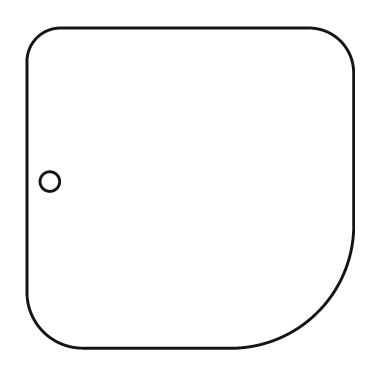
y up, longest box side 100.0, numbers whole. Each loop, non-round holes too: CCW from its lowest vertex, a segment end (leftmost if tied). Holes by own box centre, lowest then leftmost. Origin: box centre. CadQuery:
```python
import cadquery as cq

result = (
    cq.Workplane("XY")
    .moveTo(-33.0, -49.0)
    .lineTo(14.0, -49.0)
    .threePointArc((39.0, -38.0), (50.0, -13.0))
    .lineTo(50.0, 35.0)
    .threePointArc((46.0, 45.0), (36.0, 49.0))
    .lineTo(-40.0, 49.0)
    .threePointArc((-47.0, 46.0), (-50.0, 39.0))
    .lineTo(-50.0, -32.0)
    .threePointArc((-45.0, -44.0), (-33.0, -49.0))
    .close()
    .moveTo(-43.0, 2.0)
    .circle(3.0)
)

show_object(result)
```